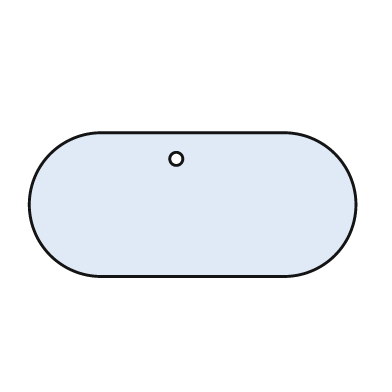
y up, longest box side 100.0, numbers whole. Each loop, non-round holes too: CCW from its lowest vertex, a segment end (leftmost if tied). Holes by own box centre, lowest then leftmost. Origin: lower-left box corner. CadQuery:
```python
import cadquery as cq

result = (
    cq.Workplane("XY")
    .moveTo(22.0, 0.0)
    .lineTo(78.0, 0.0)
    .threePointArc((100.0, 22.0), (78.0, 44.0))
    .lineTo(22.0, 44.0)
    .threePointArc((0.0, 22.0), (22.0, 0.0))
    .close()
    .moveTo(45.0, 36.0)
    .circle(2.0)
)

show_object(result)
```